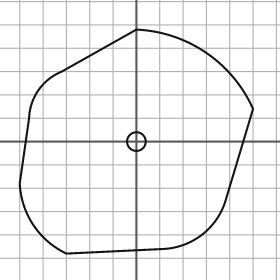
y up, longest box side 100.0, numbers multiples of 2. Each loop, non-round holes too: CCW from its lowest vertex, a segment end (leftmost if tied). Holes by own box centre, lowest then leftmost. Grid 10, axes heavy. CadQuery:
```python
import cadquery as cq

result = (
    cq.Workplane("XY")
    .moveTo(-30.0, -48.0)
    .lineTo(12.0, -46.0)
    .threePointArc((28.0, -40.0), (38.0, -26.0))
    .lineTo(50.0, 14.0)
    .threePointArc((30.0, 38.0), (0.0, 48.0))
    .lineTo(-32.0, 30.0)
    .threePointArc((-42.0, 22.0), (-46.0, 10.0))
    .lineTo(-50.0, -18.0)
    .threePointArc((-44.0, -36.0), (-30.0, -48.0))
    .close()
    .moveTo(0.0, 0.0)
    .circle(4.0)
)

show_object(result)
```